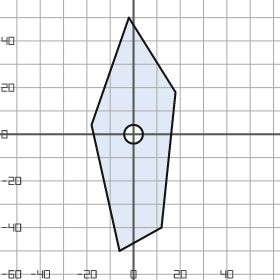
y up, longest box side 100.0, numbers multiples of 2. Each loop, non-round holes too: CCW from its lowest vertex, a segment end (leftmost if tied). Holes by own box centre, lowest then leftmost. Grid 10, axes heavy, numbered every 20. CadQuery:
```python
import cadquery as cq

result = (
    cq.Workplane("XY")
    .moveTo(-6.0, -50.0)
    .lineTo(12.0, -40.0)
    .lineTo(18.0, 18.0)
    .lineTo(-2.0, 50.0)
    .lineTo(-18.0, 4.0)
    .close()
    .moveTo(0.0, 0.0)
    .circle(4.0)
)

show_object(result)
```